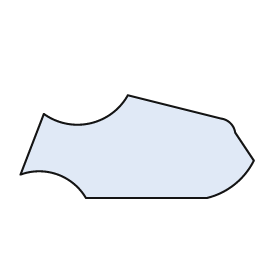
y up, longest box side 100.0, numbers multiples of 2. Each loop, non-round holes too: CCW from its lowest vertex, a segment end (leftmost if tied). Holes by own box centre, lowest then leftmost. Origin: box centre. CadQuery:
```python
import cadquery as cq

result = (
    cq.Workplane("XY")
    .moveTo(-22.0, -22.0)
    .lineTo(30.0, -22.0)
    .threePointArc((42.0, -16.0), (50.0, -6.0))
    .lineTo(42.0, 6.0)
    .threePointArc((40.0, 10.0), (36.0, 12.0))
    .lineTo(-4.0, 22.0)
    .threePointArc((-20.0, 10.0), (-40.0, 14.0))
    .lineTo(-50.0, -12.0)
    .threePointArc((-34.0, -12.0), (-22.0, -22.0))
    .close()
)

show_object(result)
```